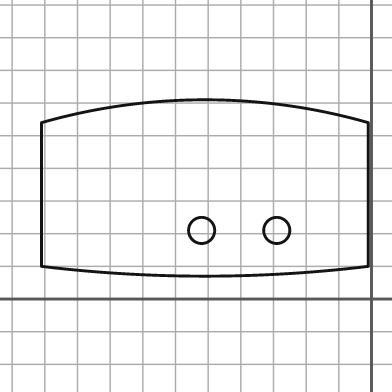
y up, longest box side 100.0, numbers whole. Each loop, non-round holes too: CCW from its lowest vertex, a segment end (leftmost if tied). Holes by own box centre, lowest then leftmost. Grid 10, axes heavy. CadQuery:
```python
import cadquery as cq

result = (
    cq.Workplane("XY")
    .moveTo(-101.0, 10.0)
    .threePointArc((-51.0, 7.0), (-1.0, 10.0))
    .lineTo(-1.0, 54.0)
    .threePointArc((-51.0, 61.0), (-101.0, 54.0))
    .close()
    .moveTo(-52.0, 21.0)
    .circle(4.0)
    .moveTo(-29.0, 21.0)
    .circle(4.0)
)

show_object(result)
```